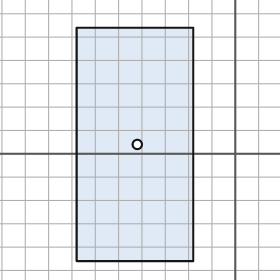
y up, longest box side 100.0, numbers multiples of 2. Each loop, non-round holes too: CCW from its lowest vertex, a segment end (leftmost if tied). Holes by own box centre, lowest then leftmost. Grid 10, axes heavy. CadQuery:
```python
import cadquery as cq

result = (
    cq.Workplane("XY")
    .moveTo(-68.0, -46.0)
    .lineTo(-18.0, -46.0)
    .lineTo(-18.0, 54.0)
    .lineTo(-68.0, 54.0)
    .close()
    .moveTo(-42.0, 4.0)
    .circle(2.0)
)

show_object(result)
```